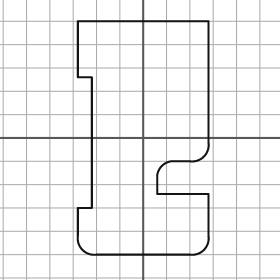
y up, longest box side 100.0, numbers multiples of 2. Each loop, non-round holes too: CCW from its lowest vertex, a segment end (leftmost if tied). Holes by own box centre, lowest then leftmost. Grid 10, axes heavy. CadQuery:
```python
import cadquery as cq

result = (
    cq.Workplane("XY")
    .moveTo(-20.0, -50.0)
    .lineTo(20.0, -50.0)
    .threePointArc((26.0, -48.0), (28.0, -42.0))
    .lineTo(28.0, -24.0)
    .lineTo(6.0, -24.0)
    .lineTo(6.0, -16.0)
    .threePointArc((8.0, -12.0), (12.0, -10.0))
    .lineTo(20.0, -10.0)
    .threePointArc((26.0, -8.0), (28.0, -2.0))
    .lineTo(28.0, 50.0)
    .lineTo(-28.0, 50.0)
    .lineTo(-28.0, 26.0)
    .lineTo(-22.0, 26.0)
    .lineTo(-22.0, -30.0)
    .lineTo(-28.0, -30.0)
    .lineTo(-28.0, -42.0)
    .threePointArc((-26.0, -48.0), (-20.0, -50.0))
    .close()
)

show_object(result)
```